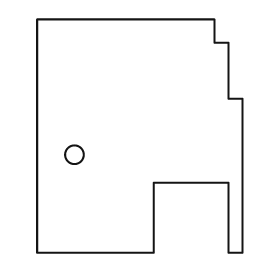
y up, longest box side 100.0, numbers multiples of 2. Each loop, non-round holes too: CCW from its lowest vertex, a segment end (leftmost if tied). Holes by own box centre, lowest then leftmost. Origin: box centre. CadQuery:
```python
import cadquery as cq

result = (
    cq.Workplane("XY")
    .moveTo(-44.0, -50.0)
    .lineTo(6.0, -50.0)
    .lineTo(6.0, -20.0)
    .lineTo(38.0, -20.0)
    .lineTo(38.0, -50.0)
    .lineTo(44.0, -50.0)
    .lineTo(44.0, 16.0)
    .lineTo(38.0, 16.0)
    .lineTo(38.0, 40.0)
    .lineTo(32.0, 40.0)
    .lineTo(32.0, 50.0)
    .lineTo(-44.0, 50.0)
    .close()
    .moveTo(-28.0, -8.0)
    .circle(4.0)
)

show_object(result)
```